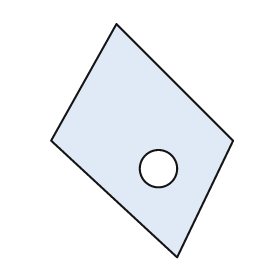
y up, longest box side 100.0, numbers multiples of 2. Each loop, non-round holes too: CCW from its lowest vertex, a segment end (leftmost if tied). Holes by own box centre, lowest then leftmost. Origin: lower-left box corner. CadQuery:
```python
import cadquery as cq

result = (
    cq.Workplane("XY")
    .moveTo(54.0, 0.0)
    .lineTo(78.0, 50.0)
    .lineTo(28.0, 100.0)
    .lineTo(0.0, 50.0)
    .close()
    .moveTo(46.0, 38.0)
    .circle(8.0)
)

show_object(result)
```